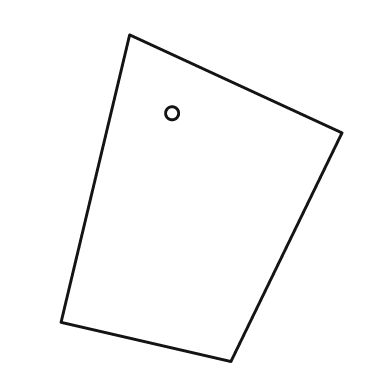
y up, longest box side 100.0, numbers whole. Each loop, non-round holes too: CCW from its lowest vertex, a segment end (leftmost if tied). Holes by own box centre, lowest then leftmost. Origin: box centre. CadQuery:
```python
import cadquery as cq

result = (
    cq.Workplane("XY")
    .moveTo(9.0, -50.0)
    .lineTo(43.0, 20.0)
    .lineTo(-22.0, 50.0)
    .lineTo(-43.0, -38.0)
    .close()
    .moveTo(-9.0, 26.0)
    .circle(2.0)
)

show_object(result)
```